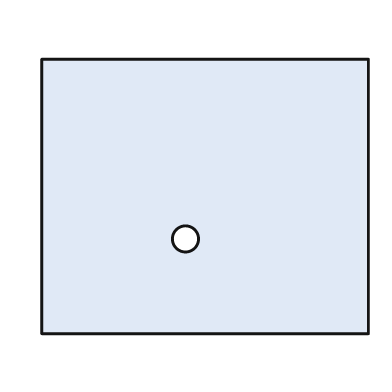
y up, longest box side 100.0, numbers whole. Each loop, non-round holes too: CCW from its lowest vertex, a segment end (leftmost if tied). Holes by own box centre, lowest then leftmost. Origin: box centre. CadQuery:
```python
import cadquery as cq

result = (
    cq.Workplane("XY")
    .moveTo(-50.0, -42.0)
    .lineTo(50.0, -42.0)
    .lineTo(50.0, 42.0)
    .lineTo(-50.0, 42.0)
    .close()
    .moveTo(-6.0, -13.0)
    .circle(4.0)
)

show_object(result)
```